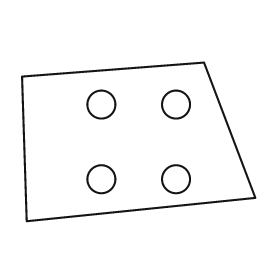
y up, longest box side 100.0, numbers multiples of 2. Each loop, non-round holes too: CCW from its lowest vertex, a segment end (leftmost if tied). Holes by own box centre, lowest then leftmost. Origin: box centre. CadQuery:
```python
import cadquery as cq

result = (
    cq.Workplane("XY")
    .moveTo(-48.0, -34.0)
    .lineTo(50.0, -24.0)
    .lineTo(28.0, 34.0)
    .lineTo(-50.0, 28.0)
    .close()
    .moveTo(-16.0, -16.0)
    .circle(6.0)
    .moveTo(16.0, -16.0)
    .circle(6.0)
    .moveTo(-16.0, 16.0)
    .circle(6.0)
    .moveTo(16.0, 16.0)
    .circle(6.0)
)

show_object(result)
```